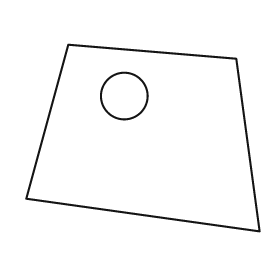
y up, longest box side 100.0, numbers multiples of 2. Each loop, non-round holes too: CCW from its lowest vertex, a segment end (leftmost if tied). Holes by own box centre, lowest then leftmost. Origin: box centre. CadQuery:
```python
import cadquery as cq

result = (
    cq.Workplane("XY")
    .moveTo(50.0, -40.0)
    .lineTo(40.0, 34.0)
    .lineTo(-32.0, 40.0)
    .lineTo(-50.0, -26.0)
    .close()
    .moveTo(-8.0, 18.0)
    .circle(10.0)
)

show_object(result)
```